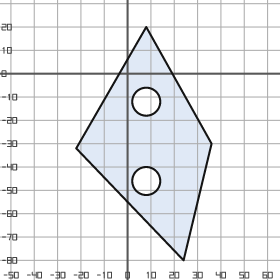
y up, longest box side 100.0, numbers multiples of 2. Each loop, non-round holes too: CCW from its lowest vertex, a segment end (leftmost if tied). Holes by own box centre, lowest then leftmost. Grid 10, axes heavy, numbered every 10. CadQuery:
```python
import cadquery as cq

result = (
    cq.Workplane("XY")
    .moveTo(24.0, -80.0)
    .lineTo(36.0, -30.0)
    .lineTo(8.0, 20.0)
    .lineTo(-22.0, -32.0)
    .close()
    .moveTo(8.0, -46.0)
    .circle(6.0)
    .moveTo(8.0, -12.0)
    .circle(6.0)
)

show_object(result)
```